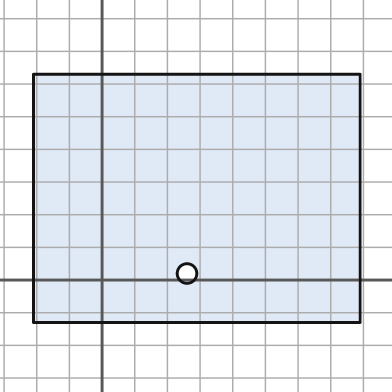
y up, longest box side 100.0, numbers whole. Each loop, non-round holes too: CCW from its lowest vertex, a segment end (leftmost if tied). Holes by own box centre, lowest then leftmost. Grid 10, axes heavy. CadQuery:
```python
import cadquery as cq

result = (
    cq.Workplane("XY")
    .moveTo(-21.0, -13.0)
    .lineTo(79.0, -13.0)
    .lineTo(79.0, 63.0)
    .lineTo(-21.0, 63.0)
    .close()
    .moveTo(26.0, 2.0)
    .circle(3.0)
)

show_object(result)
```